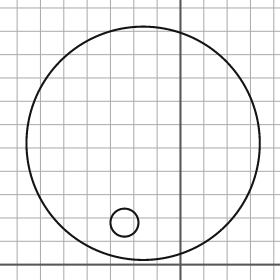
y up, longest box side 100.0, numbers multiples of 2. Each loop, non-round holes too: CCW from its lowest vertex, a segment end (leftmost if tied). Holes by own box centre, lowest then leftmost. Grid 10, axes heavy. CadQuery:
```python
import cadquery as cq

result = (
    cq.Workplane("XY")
    .moveTo(-16.0, 52.0)
    .circle(50.0)
    .moveTo(-24.0, 18.0)
    .circle(6.0)
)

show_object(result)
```